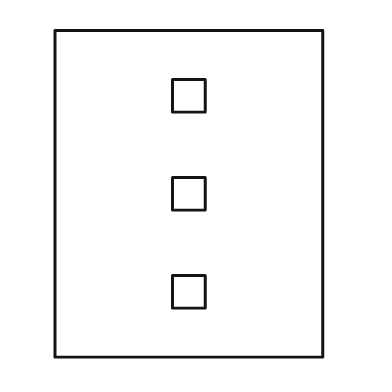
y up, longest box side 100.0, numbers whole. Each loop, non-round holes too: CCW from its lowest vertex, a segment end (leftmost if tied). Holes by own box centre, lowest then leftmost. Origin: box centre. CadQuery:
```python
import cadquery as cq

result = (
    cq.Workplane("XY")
    .moveTo(-41.0, -50.0)
    .lineTo(41.0, -50.0)
    .lineTo(41.0, 50.0)
    .lineTo(-41.0, 50.0)
    .close()
    .moveTo(-5.0, -35.0)
    .lineTo(5.0, -35.0)
    .lineTo(5.0, -25.0)
    .lineTo(-5.0, -25.0)
    .close()
    .moveTo(-5.0, -5.0)
    .lineTo(5.0, -5.0)
    .lineTo(5.0, 5.0)
    .lineTo(-5.0, 5.0)
    .close()
    .moveTo(-5.0, 25.0)
    .lineTo(5.0, 25.0)
    .lineTo(5.0, 35.0)
    .lineTo(-5.0, 35.0)
    .close()
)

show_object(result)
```